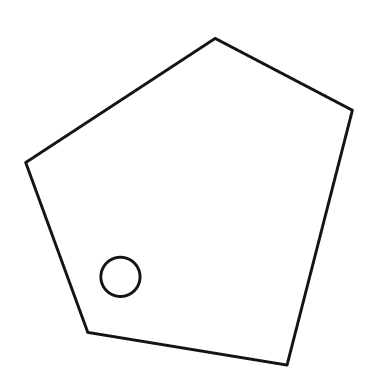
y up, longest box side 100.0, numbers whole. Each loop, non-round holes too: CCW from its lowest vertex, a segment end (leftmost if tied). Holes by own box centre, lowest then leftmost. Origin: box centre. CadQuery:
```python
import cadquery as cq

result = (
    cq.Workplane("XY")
    .moveTo(30.0, -50.0)
    .lineTo(50.0, 28.0)
    .lineTo(8.0, 50.0)
    .lineTo(-50.0, 12.0)
    .lineTo(-31.0, -40.0)
    .close()
    .moveTo(-21.0, -23.0)
    .circle(6.0)
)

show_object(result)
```